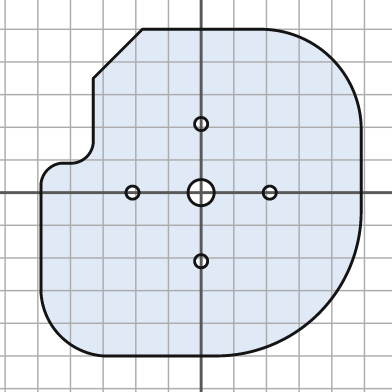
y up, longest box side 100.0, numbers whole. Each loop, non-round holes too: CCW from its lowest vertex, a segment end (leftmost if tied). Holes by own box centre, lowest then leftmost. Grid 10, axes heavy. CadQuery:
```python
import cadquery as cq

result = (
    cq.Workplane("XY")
    .moveTo(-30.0, -50.0)
    .lineTo(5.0, -50.0)
    .threePointArc((36.0, -37.0), (49.0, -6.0))
    .lineTo(49.0, 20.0)
    .threePointArc((40.0, 41.0), (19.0, 50.0))
    .lineTo(-18.0, 50.0)
    .lineTo(-33.0, 35.0)
    .lineTo(-33.0, 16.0)
    .threePointArc((-35.0, 11.0), (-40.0, 9.0))
    .lineTo(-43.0, 9.0)
    .threePointArc((-47.0, 7.0), (-49.0, 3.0))
    .lineTo(-49.0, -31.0)
    .threePointArc((-43.0, -44.0), (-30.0, -50.0))
    .close()
    .moveTo(0.0, -21.0)
    .circle(2.0)
    .moveTo(-21.0, 0.0)
    .circle(2.0)
    .moveTo(0.0, 0.0)
    .circle(4.0)
    .moveTo(21.0, 0.0)
    .circle(2.0)
    .moveTo(0.0, 21.0)
    .circle(2.0)
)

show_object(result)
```